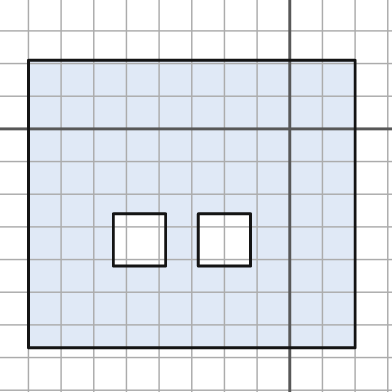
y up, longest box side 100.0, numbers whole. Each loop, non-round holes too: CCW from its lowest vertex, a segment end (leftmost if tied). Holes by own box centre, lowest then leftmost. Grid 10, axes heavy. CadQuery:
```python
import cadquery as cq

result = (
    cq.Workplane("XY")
    .moveTo(-80.0, -67.0)
    .lineTo(20.0, -67.0)
    .lineTo(20.0, 21.0)
    .lineTo(-80.0, 21.0)
    .close()
    .moveTo(-54.0, -42.0)
    .lineTo(-38.0, -42.0)
    .lineTo(-38.0, -26.0)
    .lineTo(-54.0, -26.0)
    .close()
    .moveTo(-28.0, -42.0)
    .lineTo(-12.0, -42.0)
    .lineTo(-12.0, -26.0)
    .lineTo(-28.0, -26.0)
    .close()
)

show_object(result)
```